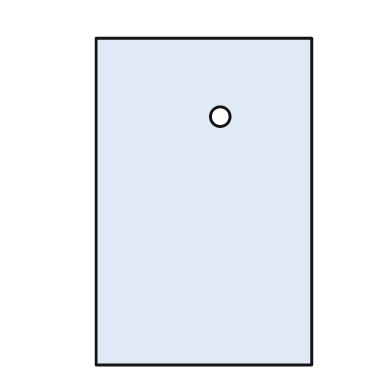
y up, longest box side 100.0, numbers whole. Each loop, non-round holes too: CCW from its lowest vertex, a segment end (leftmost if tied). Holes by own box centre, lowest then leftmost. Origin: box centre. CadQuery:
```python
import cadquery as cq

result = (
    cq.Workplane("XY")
    .moveTo(-33.0, -50.0)
    .lineTo(33.0, -50.0)
    .lineTo(33.0, 50.0)
    .lineTo(-33.0, 50.0)
    .close()
    .moveTo(5.0, 26.0)
    .circle(3.0)
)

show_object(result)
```